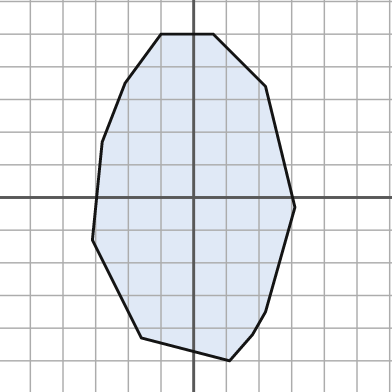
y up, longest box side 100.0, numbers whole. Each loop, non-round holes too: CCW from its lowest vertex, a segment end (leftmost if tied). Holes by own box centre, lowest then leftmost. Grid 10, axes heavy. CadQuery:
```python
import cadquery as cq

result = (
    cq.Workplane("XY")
    .moveTo(11.0, -50.0)
    .lineTo(18.0, -42.0)
    .lineTo(22.0, -35.0)
    .lineTo(31.0, -3.0)
    .lineTo(22.0, 34.0)
    .lineTo(6.0, 50.0)
    .lineTo(-10.0, 50.0)
    .lineTo(-21.0, 35.0)
    .lineTo(-28.0, 17.0)
    .lineTo(-31.0, -13.0)
    .lineTo(-16.0, -43.0)
    .close()
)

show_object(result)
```